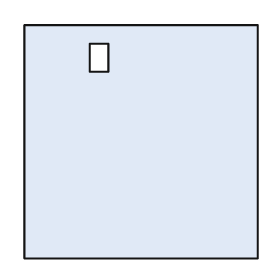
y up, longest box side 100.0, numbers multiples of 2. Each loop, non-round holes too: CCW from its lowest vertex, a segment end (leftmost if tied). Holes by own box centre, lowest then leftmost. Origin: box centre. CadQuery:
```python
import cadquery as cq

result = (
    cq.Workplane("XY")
    .moveTo(-50.0, -50.0)
    .lineTo(50.0, -50.0)
    .lineTo(50.0, 50.0)
    .lineTo(-50.0, 50.0)
    .close()
    .moveTo(-22.0, 30.0)
    .lineTo(-14.0, 30.0)
    .lineTo(-14.0, 42.0)
    .lineTo(-22.0, 42.0)
    .close()
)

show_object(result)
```